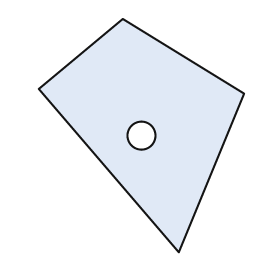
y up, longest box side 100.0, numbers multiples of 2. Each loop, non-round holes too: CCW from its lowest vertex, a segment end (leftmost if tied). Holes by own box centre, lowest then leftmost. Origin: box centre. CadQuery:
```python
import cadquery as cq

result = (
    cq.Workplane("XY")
    .moveTo(16.0, -50.0)
    .lineTo(44.0, 18.0)
    .lineTo(-8.0, 50.0)
    .lineTo(-44.0, 20.0)
    .close()
    .moveTo(0.0, 0.0)
    .circle(6.0)
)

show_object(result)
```